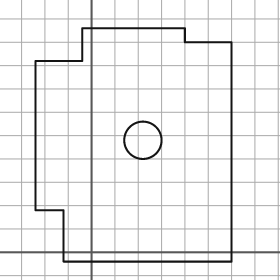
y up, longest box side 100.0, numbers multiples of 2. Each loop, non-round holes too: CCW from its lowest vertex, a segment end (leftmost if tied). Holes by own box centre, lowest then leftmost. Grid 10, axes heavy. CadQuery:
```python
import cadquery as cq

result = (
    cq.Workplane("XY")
    .moveTo(-12.0, -4.0)
    .lineTo(60.0, -4.0)
    .lineTo(60.0, 90.0)
    .lineTo(40.0, 90.0)
    .lineTo(40.0, 96.0)
    .lineTo(-4.0, 96.0)
    .lineTo(-4.0, 82.0)
    .lineTo(-24.0, 82.0)
    .lineTo(-24.0, 18.0)
    .lineTo(-12.0, 18.0)
    .close()
    .moveTo(22.0, 48.0)
    .circle(8.0)
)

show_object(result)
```